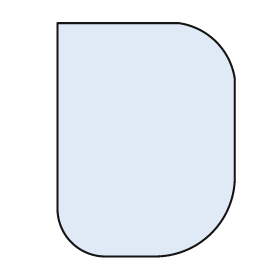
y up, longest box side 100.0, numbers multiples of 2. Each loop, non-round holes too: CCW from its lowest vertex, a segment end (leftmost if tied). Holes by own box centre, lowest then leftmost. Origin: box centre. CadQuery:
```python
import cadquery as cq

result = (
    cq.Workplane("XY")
    .moveTo(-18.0, -50.0)
    .lineTo(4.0, -50.0)
    .threePointArc((28.0, -40.0), (38.0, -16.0))
    .lineTo(38.0, 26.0)
    .threePointArc((30.0, 42.0), (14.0, 50.0))
    .lineTo(-38.0, 50.0)
    .lineTo(-38.0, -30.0)
    .threePointArc((-32.0, -44.0), (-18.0, -50.0))
    .close()
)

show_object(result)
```